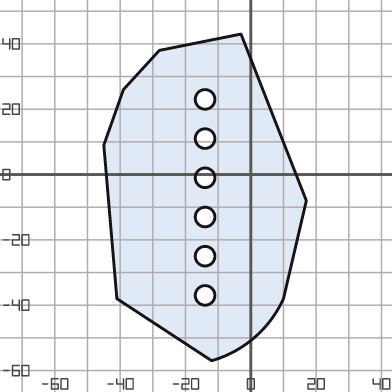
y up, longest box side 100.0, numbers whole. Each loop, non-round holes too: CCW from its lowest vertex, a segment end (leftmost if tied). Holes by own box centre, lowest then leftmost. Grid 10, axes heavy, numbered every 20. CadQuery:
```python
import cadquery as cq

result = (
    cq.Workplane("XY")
    .moveTo(-12.0, -57.0)
    .threePointArc((1.0, -50.0), (10.0, -38.0))
    .lineTo(17.0, -8.0)
    .lineTo(-3.0, 43.0)
    .lineTo(-28.0, 38.0)
    .lineTo(-39.0, 26.0)
    .lineTo(-45.0, 9.0)
    .lineTo(-41.0, -38.0)
    .close()
    .moveTo(-14.0, -37.0)
    .circle(3.0)
    .moveTo(-14.0, -25.0)
    .circle(3.0)
    .moveTo(-14.0, -13.0)
    .circle(3.0)
    .moveTo(-14.0, -1.0)
    .circle(3.0)
    .moveTo(-14.0, 11.0)
    .circle(3.0)
    .moveTo(-14.0, 23.0)
    .circle(3.0)
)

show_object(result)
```